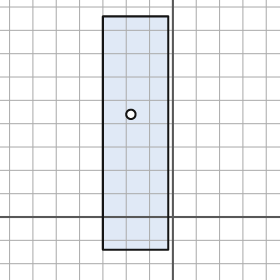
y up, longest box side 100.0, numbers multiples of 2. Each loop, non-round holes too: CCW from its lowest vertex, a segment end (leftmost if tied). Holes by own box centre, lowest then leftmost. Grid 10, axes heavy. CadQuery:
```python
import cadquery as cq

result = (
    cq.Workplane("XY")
    .moveTo(-30.0, -14.0)
    .lineTo(-2.0, -14.0)
    .lineTo(-2.0, 86.0)
    .lineTo(-30.0, 86.0)
    .close()
    .moveTo(-18.0, 44.0)
    .circle(2.0)
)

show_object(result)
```